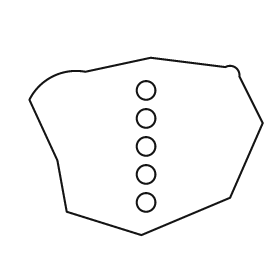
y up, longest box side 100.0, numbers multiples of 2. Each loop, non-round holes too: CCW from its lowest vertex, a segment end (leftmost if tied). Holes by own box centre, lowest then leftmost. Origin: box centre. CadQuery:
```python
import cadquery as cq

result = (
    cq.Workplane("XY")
    .moveTo(-2.0, -38.0)
    .lineTo(36.0, -22.0)
    .lineTo(50.0, 10.0)
    .lineTo(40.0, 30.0)
    .threePointArc((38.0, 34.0), (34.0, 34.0))
    .lineTo(2.0, 38.0)
    .lineTo(-26.0, 32.0)
    .threePointArc((-40.0, 30.0), (-50.0, 20.0))
    .lineTo(-38.0, -6.0)
    .lineTo(-34.0, -28.0)
    .close()
    .moveTo(0.0, -24.0)
    .circle(4.0)
    .moveTo(0.0, -12.0)
    .circle(4.0)
    .moveTo(0.0, 0.0)
    .circle(4.0)
    .moveTo(0.0, 12.0)
    .circle(4.0)
    .moveTo(0.0, 24.0)
    .circle(4.0)
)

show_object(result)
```